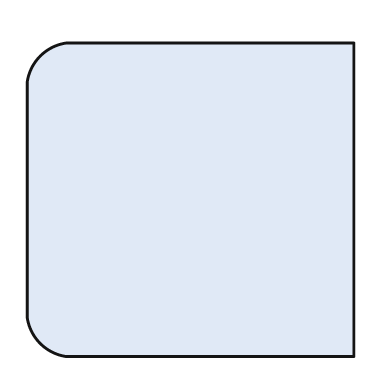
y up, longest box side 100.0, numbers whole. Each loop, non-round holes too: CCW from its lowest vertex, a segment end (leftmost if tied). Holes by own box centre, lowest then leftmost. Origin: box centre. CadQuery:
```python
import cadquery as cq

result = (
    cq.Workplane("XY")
    .moveTo(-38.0, -48.0)
    .lineTo(50.0, -48.0)
    .lineTo(50.0, 48.0)
    .lineTo(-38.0, 48.0)
    .threePointArc((-46.0, 44.0), (-50.0, 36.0))
    .lineTo(-50.0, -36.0)
    .threePointArc((-46.0, -44.0), (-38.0, -48.0))
    .close()
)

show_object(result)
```